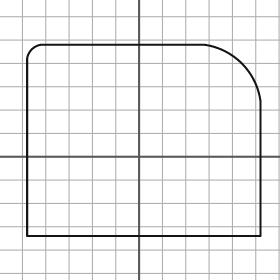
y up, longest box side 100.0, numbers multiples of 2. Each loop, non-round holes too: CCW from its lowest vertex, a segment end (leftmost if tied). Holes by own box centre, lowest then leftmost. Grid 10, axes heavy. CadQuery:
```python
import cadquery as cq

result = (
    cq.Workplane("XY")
    .moveTo(-48.0, -34.0)
    .lineTo(52.0, -34.0)
    .lineTo(52.0, 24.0)
    .threePointArc((44.0, 40.0), (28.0, 48.0))
    .lineTo(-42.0, 48.0)
    .threePointArc((-46.0, 46.0), (-48.0, 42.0))
    .close()
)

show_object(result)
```